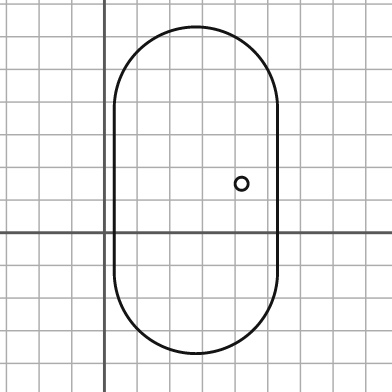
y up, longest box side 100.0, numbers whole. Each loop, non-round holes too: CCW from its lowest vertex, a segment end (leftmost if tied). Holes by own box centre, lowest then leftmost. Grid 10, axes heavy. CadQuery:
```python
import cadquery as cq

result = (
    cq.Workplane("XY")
    .moveTo(3.0, -12.0)
    .threePointArc((28.0, -37.0), (53.0, -12.0))
    .lineTo(53.0, 38.0)
    .threePointArc((28.0, 63.0), (3.0, 38.0))
    .close()
    .moveTo(42.0, 15.0)
    .circle(2.0)
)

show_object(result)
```